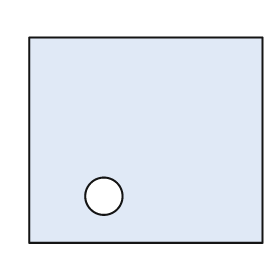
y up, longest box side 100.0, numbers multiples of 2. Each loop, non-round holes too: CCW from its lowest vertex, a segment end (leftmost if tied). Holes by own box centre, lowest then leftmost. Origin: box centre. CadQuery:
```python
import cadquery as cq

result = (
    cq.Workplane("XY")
    .moveTo(-50.0, -44.0)
    .lineTo(50.0, -44.0)
    .lineTo(50.0, 44.0)
    .lineTo(-50.0, 44.0)
    .close()
    .moveTo(-18.0, -24.0)
    .circle(8.0)
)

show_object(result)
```